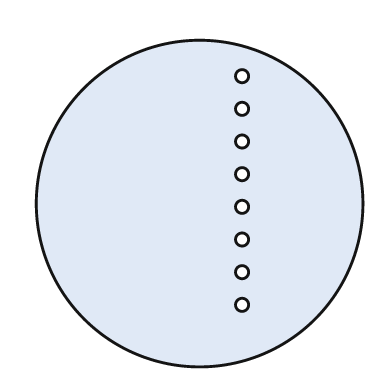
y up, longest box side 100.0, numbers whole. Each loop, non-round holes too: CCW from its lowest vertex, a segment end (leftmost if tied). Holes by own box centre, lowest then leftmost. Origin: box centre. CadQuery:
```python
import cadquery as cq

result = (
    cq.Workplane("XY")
    .moveTo(0.0, 0.0)
    .circle(50.0)
    .moveTo(13.0, -31.0)
    .circle(2.0)
    .moveTo(13.0, -21.0)
    .circle(2.0)
    .moveTo(13.0, -11.0)
    .circle(2.0)
    .moveTo(13.0, -1.0)
    .circle(2.0)
    .moveTo(13.0, 9.0)
    .circle(2.0)
    .moveTo(13.0, 19.0)
    .circle(2.0)
    .moveTo(13.0, 29.0)
    .circle(2.0)
    .moveTo(13.0, 39.0)
    .circle(2.0)
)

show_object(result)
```